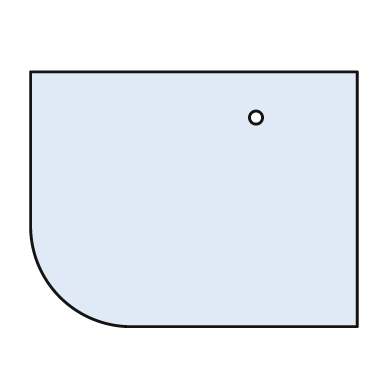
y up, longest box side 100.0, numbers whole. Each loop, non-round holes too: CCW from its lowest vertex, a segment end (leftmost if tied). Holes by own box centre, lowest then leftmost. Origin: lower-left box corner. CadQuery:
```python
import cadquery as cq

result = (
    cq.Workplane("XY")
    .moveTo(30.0, 0.0)
    .lineTo(100.0, 0.0)
    .lineTo(100.0, 78.0)
    .lineTo(0.0, 78.0)
    .lineTo(0.0, 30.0)
    .threePointArc((9.0, 9.0), (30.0, 0.0))
    .close()
    .moveTo(69.0, 64.0)
    .circle(2.0)
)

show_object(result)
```